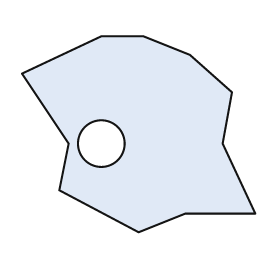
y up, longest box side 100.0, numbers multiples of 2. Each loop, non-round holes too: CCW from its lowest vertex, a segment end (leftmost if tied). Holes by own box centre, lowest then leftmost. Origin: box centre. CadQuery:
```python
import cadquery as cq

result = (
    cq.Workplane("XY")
    .moveTo(0.0, -42.0)
    .lineTo(20.0, -34.0)
    .lineTo(50.0, -34.0)
    .lineTo(36.0, -4.0)
    .lineTo(40.0, 18.0)
    .lineTo(22.0, 34.0)
    .lineTo(2.0, 42.0)
    .lineTo(-16.0, 42.0)
    .lineTo(-50.0, 26.0)
    .lineTo(-30.0, -4.0)
    .lineTo(-34.0, -24.0)
    .close()
    .moveTo(-16.0, -4.0)
    .circle(10.0)
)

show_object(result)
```